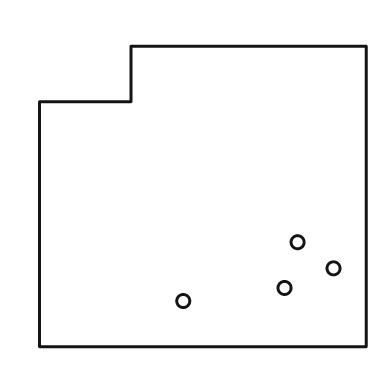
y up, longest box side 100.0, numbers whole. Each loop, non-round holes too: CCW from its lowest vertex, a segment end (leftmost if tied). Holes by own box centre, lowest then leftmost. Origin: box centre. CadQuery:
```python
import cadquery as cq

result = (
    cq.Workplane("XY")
    .moveTo(-50.0, -46.0)
    .lineTo(50.0, -46.0)
    .lineTo(50.0, 46.0)
    .lineTo(-22.0, 46.0)
    .lineTo(-22.0, 29.0)
    .lineTo(-50.0, 29.0)
    .close()
    .moveTo(-6.0, -32.0)
    .circle(2.0)
    .moveTo(25.0, -28.0)
    .circle(2.0)
    .moveTo(40.0, -22.0)
    .circle(2.0)
    .moveTo(29.0, -14.0)
    .circle(2.0)
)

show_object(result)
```